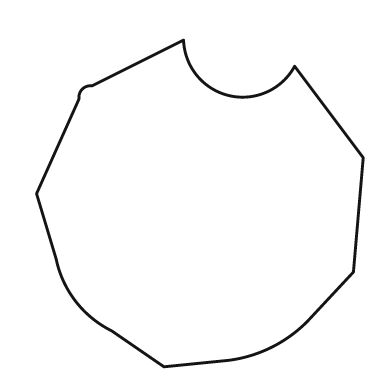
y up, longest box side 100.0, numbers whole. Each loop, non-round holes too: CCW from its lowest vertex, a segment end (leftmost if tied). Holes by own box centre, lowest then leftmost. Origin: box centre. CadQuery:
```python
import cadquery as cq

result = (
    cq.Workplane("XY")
    .moveTo(-11.0, -50.0)
    .lineTo(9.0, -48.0)
    .threePointArc((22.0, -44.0), (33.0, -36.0))
    .lineTo(47.0, -21.0)
    .lineTo(50.0, 14.0)
    .lineTo(29.0, 42.0)
    .threePointArc((9.0, 33.0), (-5.0, 50.0))
    .lineTo(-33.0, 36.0)
    .threePointArc((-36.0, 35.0), (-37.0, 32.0))
    .lineTo(-50.0, 3.0)
    .lineTo(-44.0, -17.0)
    .threePointArc((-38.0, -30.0), (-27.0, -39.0))
    .close()
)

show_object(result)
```